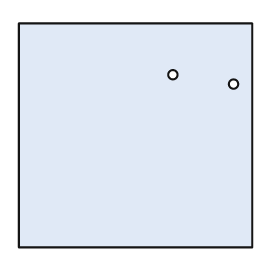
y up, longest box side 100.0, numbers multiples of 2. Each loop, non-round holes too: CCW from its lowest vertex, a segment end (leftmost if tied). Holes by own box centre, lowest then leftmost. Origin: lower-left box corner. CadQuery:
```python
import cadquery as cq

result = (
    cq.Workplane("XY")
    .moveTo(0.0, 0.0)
    .lineTo(100.0, 0.0)
    .lineTo(100.0, 96.0)
    .lineTo(0.0, 96.0)
    .close()
    .moveTo(92.0, 70.0)
    .circle(2.0)
    .moveTo(66.0, 74.0)
    .circle(2.0)
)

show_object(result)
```